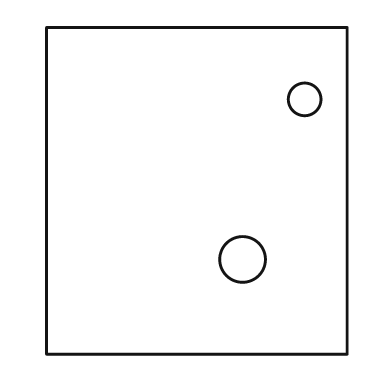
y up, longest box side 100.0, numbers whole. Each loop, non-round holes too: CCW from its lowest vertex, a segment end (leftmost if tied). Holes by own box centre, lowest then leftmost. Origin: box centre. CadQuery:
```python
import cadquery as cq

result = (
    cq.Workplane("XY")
    .moveTo(-46.0, -50.0)
    .lineTo(46.0, -50.0)
    .lineTo(46.0, 50.0)
    .lineTo(-46.0, 50.0)
    .close()
    .moveTo(14.0, -21.0)
    .circle(7.0)
    .moveTo(33.0, 28.0)
    .circle(5.0)
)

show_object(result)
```